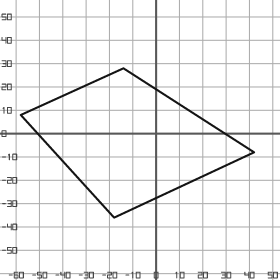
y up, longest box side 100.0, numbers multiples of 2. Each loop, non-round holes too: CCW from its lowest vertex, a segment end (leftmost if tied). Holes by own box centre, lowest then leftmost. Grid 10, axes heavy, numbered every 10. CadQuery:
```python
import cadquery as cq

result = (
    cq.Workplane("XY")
    .moveTo(-18.0, -36.0)
    .lineTo(42.0, -8.0)
    .lineTo(-14.0, 28.0)
    .lineTo(-58.0, 8.0)
    .close()
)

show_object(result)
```